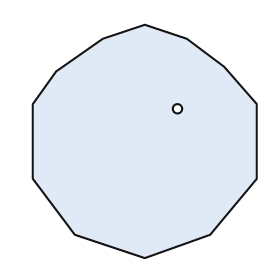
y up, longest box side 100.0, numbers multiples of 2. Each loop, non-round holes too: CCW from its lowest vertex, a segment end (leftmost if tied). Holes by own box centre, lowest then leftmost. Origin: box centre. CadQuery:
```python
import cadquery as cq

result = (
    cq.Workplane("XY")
    .moveTo(0.0, -50.0)
    .lineTo(28.0, -40.0)
    .lineTo(48.0, -16.0)
    .lineTo(48.0, 16.0)
    .lineTo(34.0, 32.0)
    .lineTo(18.0, 44.0)
    .lineTo(0.0, 50.0)
    .lineTo(-18.0, 44.0)
    .lineTo(-38.0, 30.0)
    .lineTo(-48.0, 16.0)
    .lineTo(-48.0, -16.0)
    .lineTo(-30.0, -40.0)
    .close()
    .moveTo(14.0, 14.0)
    .circle(2.0)
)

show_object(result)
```